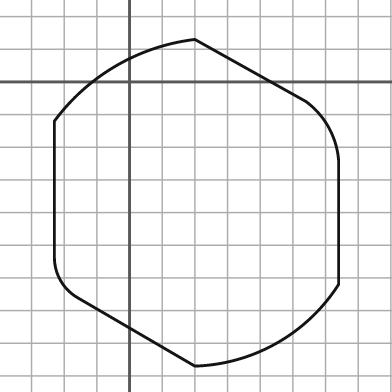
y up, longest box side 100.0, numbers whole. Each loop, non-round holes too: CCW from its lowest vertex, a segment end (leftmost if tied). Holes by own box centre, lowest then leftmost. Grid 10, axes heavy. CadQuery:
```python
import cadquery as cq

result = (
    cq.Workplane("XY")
    .moveTo(20.0, -87.0)
    .threePointArc((45.0, -80.0), (64.0, -62.0))
    .lineTo(64.0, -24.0)
    .threePointArc((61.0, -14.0), (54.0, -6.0))
    .lineTo(20.0, 13.0)
    .threePointArc((-4.0, 5.0), (-23.0, -12.0))
    .lineTo(-23.0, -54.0)
    .threePointArc((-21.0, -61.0), (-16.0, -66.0))
    .close()
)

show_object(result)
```